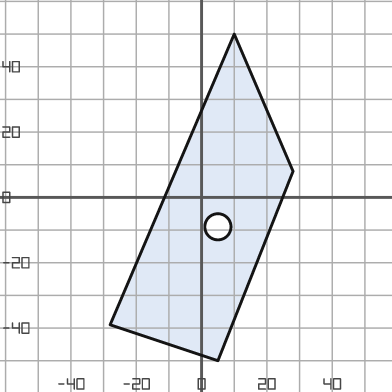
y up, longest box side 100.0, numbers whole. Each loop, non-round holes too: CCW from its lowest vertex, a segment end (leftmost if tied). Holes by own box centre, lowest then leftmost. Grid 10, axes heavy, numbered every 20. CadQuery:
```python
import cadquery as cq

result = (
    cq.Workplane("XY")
    .moveTo(5.0, -50.0)
    .lineTo(28.0, 8.0)
    .lineTo(10.0, 50.0)
    .lineTo(-28.0, -39.0)
    .close()
    .moveTo(5.0, -9.0)
    .circle(4.0)
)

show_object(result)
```